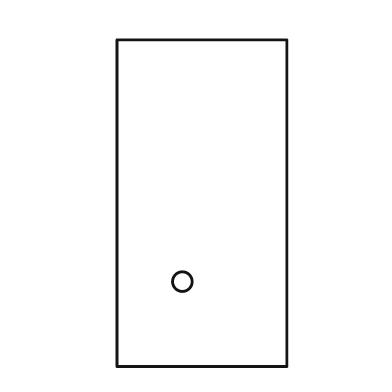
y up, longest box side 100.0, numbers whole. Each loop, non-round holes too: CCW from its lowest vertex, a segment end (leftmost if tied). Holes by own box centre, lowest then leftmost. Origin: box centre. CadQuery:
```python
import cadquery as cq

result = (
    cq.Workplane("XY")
    .moveTo(-26.0, -50.0)
    .lineTo(26.0, -50.0)
    .lineTo(26.0, 50.0)
    .lineTo(-26.0, 50.0)
    .close()
    .moveTo(-6.0, -24.0)
    .circle(3.0)
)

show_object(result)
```